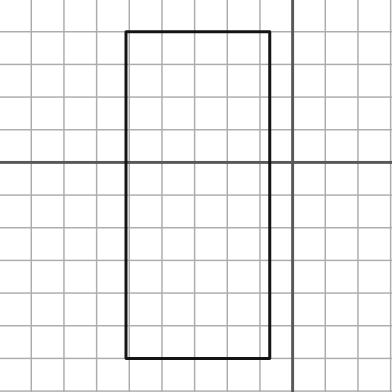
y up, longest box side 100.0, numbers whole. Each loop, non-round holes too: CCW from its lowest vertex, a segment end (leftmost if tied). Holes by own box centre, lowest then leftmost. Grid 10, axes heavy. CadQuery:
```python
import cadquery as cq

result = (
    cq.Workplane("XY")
    .moveTo(-51.0, -60.0)
    .lineTo(-7.0, -60.0)
    .lineTo(-7.0, 40.0)
    .lineTo(-51.0, 40.0)
    .close()
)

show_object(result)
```